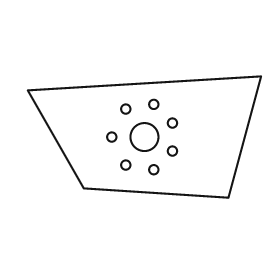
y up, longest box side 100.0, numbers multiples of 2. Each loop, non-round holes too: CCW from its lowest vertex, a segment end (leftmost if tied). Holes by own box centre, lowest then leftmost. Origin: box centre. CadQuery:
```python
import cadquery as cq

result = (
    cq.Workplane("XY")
    .moveTo(36.0, -26.0)
    .lineTo(50.0, 26.0)
    .lineTo(-50.0, 20.0)
    .lineTo(-26.0, -22.0)
    .close()
    .moveTo(4.0, -14.0)
    .circle(2.0)
    .moveTo(-8.0, -12.0)
    .circle(2.0)
    .moveTo(12.0, -6.0)
    .circle(2.0)
    .moveTo(-14.0, 0.0)
    .circle(2.0)
    .moveTo(0.0, 0.0)
    .circle(6.0)
    .moveTo(12.0, 6.0)
    .circle(2.0)
    .moveTo(-8.0, 12.0)
    .circle(2.0)
    .moveTo(4.0, 14.0)
    .circle(2.0)
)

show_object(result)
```